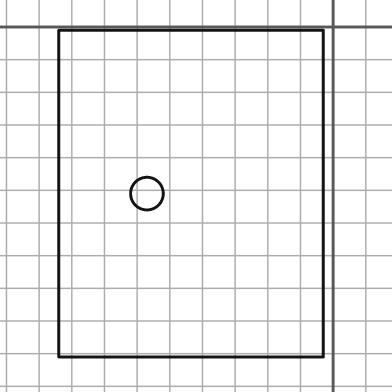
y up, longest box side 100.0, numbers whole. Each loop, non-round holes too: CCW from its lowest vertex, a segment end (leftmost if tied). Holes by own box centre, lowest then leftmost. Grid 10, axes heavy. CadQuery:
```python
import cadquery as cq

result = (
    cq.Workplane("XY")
    .moveTo(-84.0, -101.0)
    .lineTo(-3.0, -101.0)
    .lineTo(-3.0, -1.0)
    .lineTo(-84.0, -1.0)
    .close()
    .moveTo(-57.0, -51.0)
    .circle(5.0)
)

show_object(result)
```